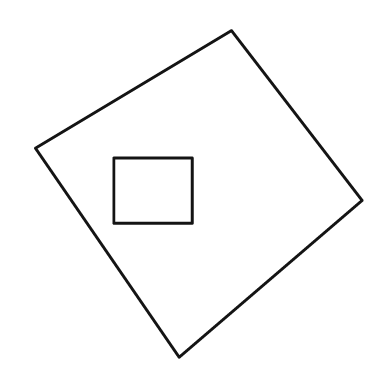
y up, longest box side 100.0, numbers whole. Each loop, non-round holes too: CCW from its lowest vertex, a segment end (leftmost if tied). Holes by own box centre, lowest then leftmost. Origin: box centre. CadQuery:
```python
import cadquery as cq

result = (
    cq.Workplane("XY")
    .moveTo(-6.0, -50.0)
    .lineTo(50.0, -2.0)
    .lineTo(10.0, 50.0)
    .lineTo(-50.0, 14.0)
    .close()
    .moveTo(-26.0, -9.0)
    .lineTo(-2.0, -9.0)
    .lineTo(-2.0, 11.0)
    .lineTo(-26.0, 11.0)
    .close()
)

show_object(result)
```